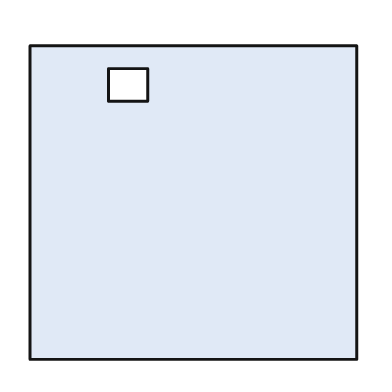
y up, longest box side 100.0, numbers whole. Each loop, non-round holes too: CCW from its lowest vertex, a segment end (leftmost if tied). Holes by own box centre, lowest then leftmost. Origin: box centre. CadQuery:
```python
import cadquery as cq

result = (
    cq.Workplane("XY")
    .moveTo(-50.0, -48.0)
    .lineTo(50.0, -48.0)
    .lineTo(50.0, 48.0)
    .lineTo(-50.0, 48.0)
    .close()
    .moveTo(-26.0, 31.0)
    .lineTo(-14.0, 31.0)
    .lineTo(-14.0, 41.0)
    .lineTo(-26.0, 41.0)
    .close()
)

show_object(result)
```